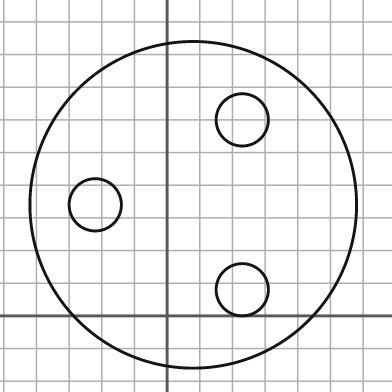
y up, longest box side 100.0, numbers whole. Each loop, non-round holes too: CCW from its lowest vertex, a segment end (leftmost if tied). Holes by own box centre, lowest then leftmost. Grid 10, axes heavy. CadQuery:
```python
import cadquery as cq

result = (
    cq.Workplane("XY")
    .moveTo(8.0, 34.0)
    .circle(50.0)
    .moveTo(23.0, 8.0)
    .circle(8.0)
    .moveTo(-22.0, 34.0)
    .circle(8.0)
    .moveTo(23.0, 60.0)
    .circle(8.0)
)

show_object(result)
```